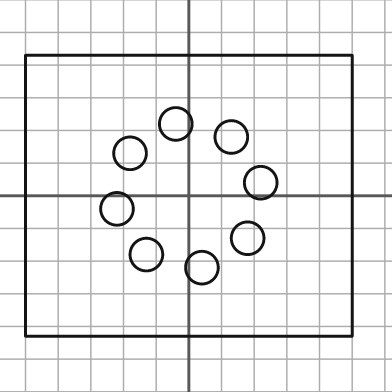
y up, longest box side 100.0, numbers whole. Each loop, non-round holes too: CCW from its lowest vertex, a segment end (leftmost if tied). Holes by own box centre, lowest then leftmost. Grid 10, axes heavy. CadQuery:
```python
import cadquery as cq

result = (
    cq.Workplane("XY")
    .moveTo(-50.0, -43.0)
    .lineTo(50.0, -43.0)
    .lineTo(50.0, 43.0)
    .lineTo(-50.0, 43.0)
    .close()
    .moveTo(4.0, -22.0)
    .circle(5.0)
    .moveTo(-13.0, -18.0)
    .circle(5.0)
    .moveTo(18.0, -13.0)
    .circle(5.0)
    .moveTo(-22.0, -4.0)
    .circle(5.0)
    .moveTo(22.0, 4.0)
    .circle(5.0)
    .moveTo(-18.0, 13.0)
    .circle(5.0)
    .moveTo(13.0, 18.0)
    .circle(5.0)
    .moveTo(-4.0, 22.0)
    .circle(5.0)
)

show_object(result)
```